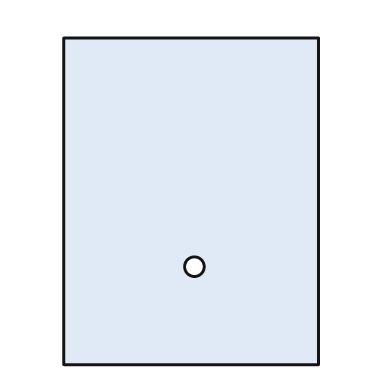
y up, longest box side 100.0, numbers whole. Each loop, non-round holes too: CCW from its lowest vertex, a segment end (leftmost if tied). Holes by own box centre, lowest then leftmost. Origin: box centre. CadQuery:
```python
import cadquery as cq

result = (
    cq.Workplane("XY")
    .moveTo(-39.0, -50.0)
    .lineTo(39.0, -50.0)
    .lineTo(39.0, 50.0)
    .lineTo(-39.0, 50.0)
    .close()
    .moveTo(1.0, -20.0)
    .circle(3.0)
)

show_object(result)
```